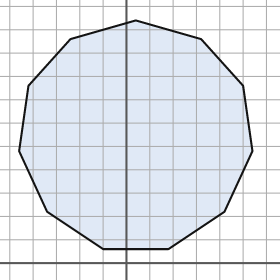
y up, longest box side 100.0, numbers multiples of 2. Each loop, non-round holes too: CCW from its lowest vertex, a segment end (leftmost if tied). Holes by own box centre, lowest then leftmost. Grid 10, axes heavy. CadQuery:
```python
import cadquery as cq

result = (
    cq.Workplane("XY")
    .moveTo(-10.0, 6.0)
    .lineTo(18.0, 6.0)
    .lineTo(42.0, 22.0)
    .lineTo(54.0, 48.0)
    .lineTo(50.0, 76.0)
    .lineTo(32.0, 96.0)
    .lineTo(4.0, 104.0)
    .lineTo(-24.0, 96.0)
    .lineTo(-42.0, 76.0)
    .lineTo(-46.0, 48.0)
    .lineTo(-34.0, 22.0)
    .close()
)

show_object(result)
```